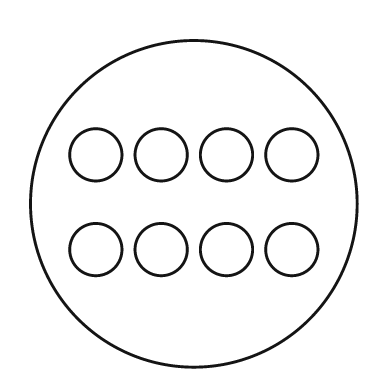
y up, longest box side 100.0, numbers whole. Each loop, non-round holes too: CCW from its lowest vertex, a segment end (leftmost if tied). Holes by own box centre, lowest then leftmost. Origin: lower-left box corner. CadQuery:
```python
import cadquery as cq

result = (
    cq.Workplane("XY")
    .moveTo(50.0, 50.0)
    .circle(50.0)
    .moveTo(20.0, 36.0)
    .circle(8.0)
    .moveTo(40.0, 36.0)
    .circle(8.0)
    .moveTo(60.0, 36.0)
    .circle(8.0)
    .moveTo(80.0, 36.0)
    .circle(8.0)
    .moveTo(20.0, 65.0)
    .circle(8.0)
    .moveTo(40.0, 65.0)
    .circle(8.0)
    .moveTo(60.0, 65.0)
    .circle(8.0)
    .moveTo(80.0, 65.0)
    .circle(8.0)
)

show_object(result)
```